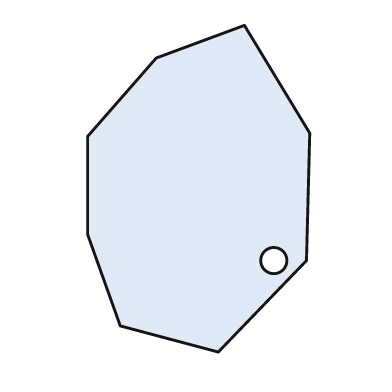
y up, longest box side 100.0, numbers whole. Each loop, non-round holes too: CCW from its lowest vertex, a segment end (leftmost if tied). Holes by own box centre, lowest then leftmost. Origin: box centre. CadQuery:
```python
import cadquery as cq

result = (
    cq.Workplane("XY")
    .moveTo(6.0, -50.0)
    .lineTo(33.0, -22.0)
    .lineTo(34.0, 17.0)
    .lineTo(14.0, 50.0)
    .lineTo(-13.0, 40.0)
    .lineTo(-34.0, 16.0)
    .lineTo(-34.0, -14.0)
    .lineTo(-24.0, -42.0)
    .close()
    .moveTo(23.0, -22.0)
    .circle(4.0)
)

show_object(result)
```